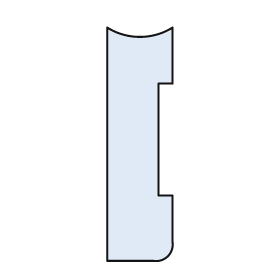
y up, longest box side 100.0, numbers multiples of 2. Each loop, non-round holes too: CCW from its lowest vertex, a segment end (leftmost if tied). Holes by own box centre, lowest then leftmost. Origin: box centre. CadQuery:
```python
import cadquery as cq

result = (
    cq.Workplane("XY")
    .moveTo(-14.0, -50.0)
    .lineTo(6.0, -50.0)
    .threePointArc((12.0, -48.0), (14.0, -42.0))
    .lineTo(14.0, -22.0)
    .lineTo(8.0, -22.0)
    .lineTo(8.0, 26.0)
    .lineTo(14.0, 26.0)
    .lineTo(14.0, 50.0)
    .threePointArc((0.0, 46.0), (-14.0, 50.0))
    .close()
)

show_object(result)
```